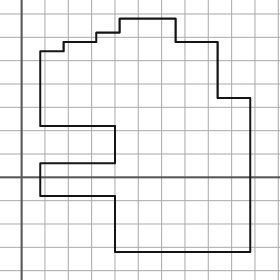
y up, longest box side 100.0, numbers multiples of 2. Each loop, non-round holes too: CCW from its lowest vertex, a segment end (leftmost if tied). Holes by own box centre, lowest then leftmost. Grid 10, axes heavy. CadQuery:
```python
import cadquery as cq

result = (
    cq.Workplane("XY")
    .moveTo(40.0, -32.0)
    .lineTo(98.0, -32.0)
    .lineTo(98.0, 34.0)
    .lineTo(84.0, 34.0)
    .lineTo(84.0, 58.0)
    .lineTo(66.0, 58.0)
    .lineTo(66.0, 68.0)
    .lineTo(42.0, 68.0)
    .lineTo(42.0, 62.0)
    .lineTo(32.0, 62.0)
    .lineTo(32.0, 58.0)
    .lineTo(18.0, 58.0)
    .lineTo(18.0, 54.0)
    .lineTo(8.0, 54.0)
    .lineTo(8.0, 22.0)
    .lineTo(40.0, 22.0)
    .lineTo(40.0, 6.0)
    .lineTo(8.0, 6.0)
    .lineTo(8.0, -8.0)
    .lineTo(40.0, -8.0)
    .close()
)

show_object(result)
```